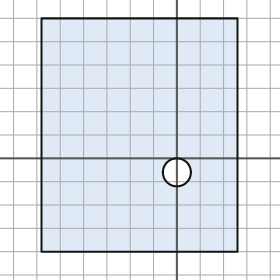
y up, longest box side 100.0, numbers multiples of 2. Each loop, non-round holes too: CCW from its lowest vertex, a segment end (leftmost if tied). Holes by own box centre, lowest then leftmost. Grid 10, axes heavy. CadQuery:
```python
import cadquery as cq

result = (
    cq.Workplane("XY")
    .moveTo(-58.0, -40.0)
    .lineTo(26.0, -40.0)
    .lineTo(26.0, 60.0)
    .lineTo(-58.0, 60.0)
    .close()
    .moveTo(0.0, -6.0)
    .circle(6.0)
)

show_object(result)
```